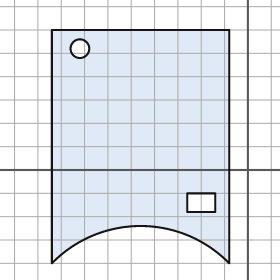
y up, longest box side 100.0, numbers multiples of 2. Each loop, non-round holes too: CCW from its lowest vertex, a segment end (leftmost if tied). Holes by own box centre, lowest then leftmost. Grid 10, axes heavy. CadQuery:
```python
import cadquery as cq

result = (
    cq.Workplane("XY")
    .moveTo(-84.0, -40.0)
    .threePointArc((-46.0, -24.0), (-8.0, -40.0))
    .lineTo(-8.0, 60.0)
    .lineTo(-84.0, 60.0)
    .close()
    .moveTo(-26.0, -18.0)
    .lineTo(-14.0, -18.0)
    .lineTo(-14.0, -10.0)
    .lineTo(-26.0, -10.0)
    .close()
    .moveTo(-72.0, 52.0)
    .circle(4.0)
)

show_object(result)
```